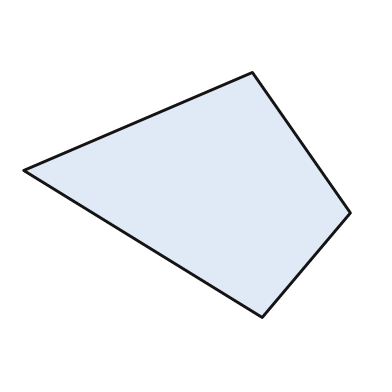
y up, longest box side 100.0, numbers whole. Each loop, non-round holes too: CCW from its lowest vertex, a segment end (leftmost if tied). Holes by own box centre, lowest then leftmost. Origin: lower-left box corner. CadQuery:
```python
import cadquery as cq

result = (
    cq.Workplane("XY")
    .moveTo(73.0, 0.0)
    .lineTo(100.0, 32.0)
    .lineTo(70.0, 75.0)
    .lineTo(0.0, 45.0)
    .close()
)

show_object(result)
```